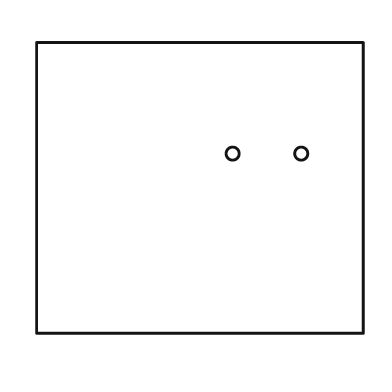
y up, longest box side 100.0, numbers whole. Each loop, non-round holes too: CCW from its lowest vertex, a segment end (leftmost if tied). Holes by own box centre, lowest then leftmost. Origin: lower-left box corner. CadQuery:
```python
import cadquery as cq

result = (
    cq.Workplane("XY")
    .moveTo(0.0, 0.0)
    .lineTo(100.0, 0.0)
    .lineTo(100.0, 89.0)
    .lineTo(0.0, 89.0)
    .close()
    .moveTo(60.0, 55.0)
    .circle(2.0)
    .moveTo(81.0, 55.0)
    .circle(2.0)
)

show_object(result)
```